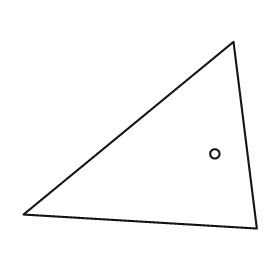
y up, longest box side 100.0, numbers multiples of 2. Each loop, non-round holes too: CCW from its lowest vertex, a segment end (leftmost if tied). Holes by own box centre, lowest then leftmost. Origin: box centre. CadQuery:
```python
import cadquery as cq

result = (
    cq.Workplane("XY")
    .moveTo(50.0, -40.0)
    .lineTo(40.0, 40.0)
    .lineTo(-50.0, -34.0)
    .close()
    .moveTo(32.0, -8.0)
    .circle(2.0)
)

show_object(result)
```